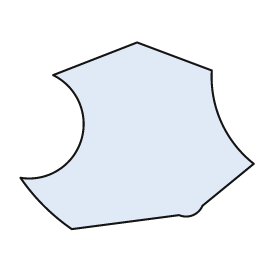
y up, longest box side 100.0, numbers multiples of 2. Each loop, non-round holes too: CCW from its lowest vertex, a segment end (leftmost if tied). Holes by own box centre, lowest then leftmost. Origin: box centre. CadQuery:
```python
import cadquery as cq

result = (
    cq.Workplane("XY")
    .moveTo(-28.0, -40.0)
    .lineTo(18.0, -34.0)
    .threePointArc((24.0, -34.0), (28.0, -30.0))
    .lineTo(50.0, -12.0)
    .threePointArc((36.0, 6.0), (32.0, 28.0))
    .lineTo(0.0, 40.0)
    .lineTo(-36.0, 26.0)
    .threePointArc((-24.0, -2.0), (-50.0, -18.0))
    .threePointArc((-40.0, -30.0), (-28.0, -40.0))
    .close()
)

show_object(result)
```